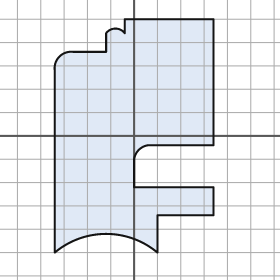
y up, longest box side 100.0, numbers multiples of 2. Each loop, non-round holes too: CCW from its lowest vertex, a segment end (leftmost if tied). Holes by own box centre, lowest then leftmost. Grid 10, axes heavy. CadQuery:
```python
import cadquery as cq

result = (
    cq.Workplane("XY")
    .moveTo(-34.0, -50.0)
    .threePointArc((-12.0, -42.0), (10.0, -50.0))
    .lineTo(10.0, -34.0)
    .lineTo(34.0, -34.0)
    .lineTo(34.0, -22.0)
    .lineTo(0.0, -22.0)
    .lineTo(0.0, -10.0)
    .threePointArc((2.0, -6.0), (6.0, -4.0))
    .lineTo(34.0, -4.0)
    .lineTo(34.0, 50.0)
    .lineTo(-4.0, 50.0)
    .lineTo(-4.0, 44.0)
    .threePointArc((-8.0, 46.0), (-12.0, 44.0))
    .lineTo(-12.0, 36.0)
    .lineTo(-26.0, 36.0)
    .threePointArc((-32.0, 34.0), (-34.0, 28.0))
    .close()
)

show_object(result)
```